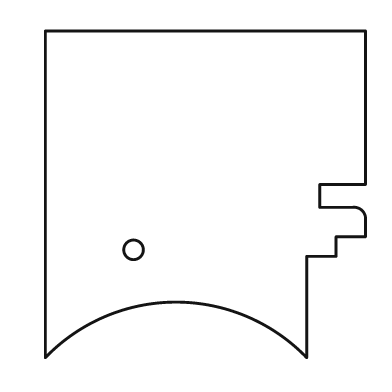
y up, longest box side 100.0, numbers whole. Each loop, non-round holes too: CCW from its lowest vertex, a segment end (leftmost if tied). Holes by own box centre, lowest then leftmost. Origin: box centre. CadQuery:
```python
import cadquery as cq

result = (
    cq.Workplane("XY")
    .moveTo(-49.0, -50.0)
    .threePointArc((-9.0, -33.0), (31.0, -50.0))
    .lineTo(31.0, -19.0)
    .lineTo(40.0, -19.0)
    .lineTo(40.0, -13.0)
    .lineTo(49.0, -13.0)
    .lineTo(49.0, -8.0)
    .threePointArc((48.0, -5.0), (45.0, -4.0))
    .lineTo(35.0, -4.0)
    .lineTo(35.0, 3.0)
    .lineTo(49.0, 3.0)
    .lineTo(49.0, 50.0)
    .lineTo(-49.0, 50.0)
    .close()
    .moveTo(-22.0, -17.0)
    .circle(3.0)
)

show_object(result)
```